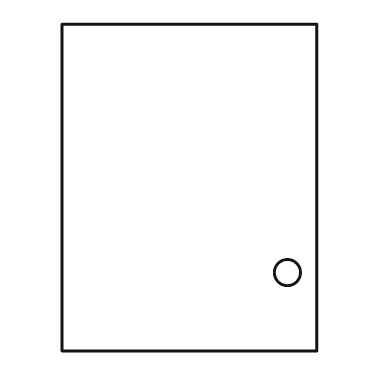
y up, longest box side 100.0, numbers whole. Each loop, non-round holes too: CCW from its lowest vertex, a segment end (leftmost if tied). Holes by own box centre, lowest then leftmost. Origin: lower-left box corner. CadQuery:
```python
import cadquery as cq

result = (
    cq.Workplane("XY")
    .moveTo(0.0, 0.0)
    .lineTo(78.0, 0.0)
    .lineTo(78.0, 100.0)
    .lineTo(0.0, 100.0)
    .close()
    .moveTo(69.0, 24.0)
    .circle(4.0)
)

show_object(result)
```